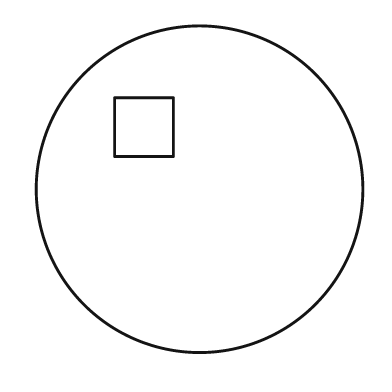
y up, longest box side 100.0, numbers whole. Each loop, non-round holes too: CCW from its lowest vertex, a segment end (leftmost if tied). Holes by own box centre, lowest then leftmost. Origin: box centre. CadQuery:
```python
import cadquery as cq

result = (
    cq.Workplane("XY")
    .moveTo(0.0, 0.0)
    .circle(50.0)
    .moveTo(-26.0, 10.0)
    .lineTo(-8.0, 10.0)
    .lineTo(-8.0, 28.0)
    .lineTo(-26.0, 28.0)
    .close()
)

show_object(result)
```